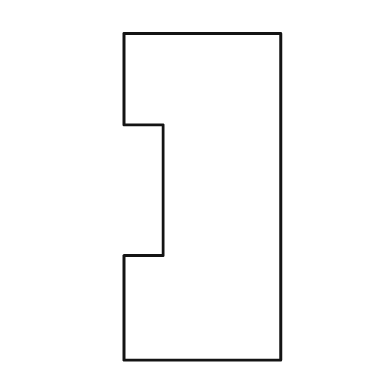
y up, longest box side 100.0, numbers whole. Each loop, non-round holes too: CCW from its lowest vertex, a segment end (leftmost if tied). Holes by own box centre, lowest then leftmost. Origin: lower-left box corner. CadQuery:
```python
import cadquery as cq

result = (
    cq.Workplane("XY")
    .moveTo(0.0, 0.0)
    .lineTo(48.0, 0.0)
    .lineTo(48.0, 100.0)
    .lineTo(0.0, 100.0)
    .lineTo(0.0, 72.0)
    .lineTo(12.0, 72.0)
    .lineTo(12.0, 32.0)
    .lineTo(0.0, 32.0)
    .close()
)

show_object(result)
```